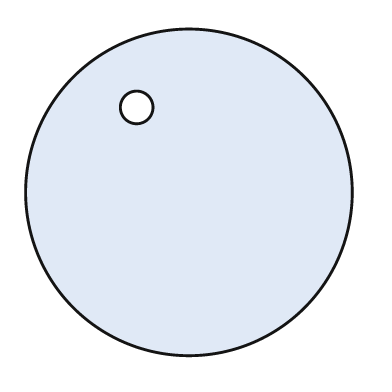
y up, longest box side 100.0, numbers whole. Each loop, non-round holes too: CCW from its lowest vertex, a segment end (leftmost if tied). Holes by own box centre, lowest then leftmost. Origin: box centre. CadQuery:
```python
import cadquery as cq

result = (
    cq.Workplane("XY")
    .moveTo(0.0, 0.0)
    .circle(50.0)
    .moveTo(-16.0, 26.0)
    .circle(5.0)
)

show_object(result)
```